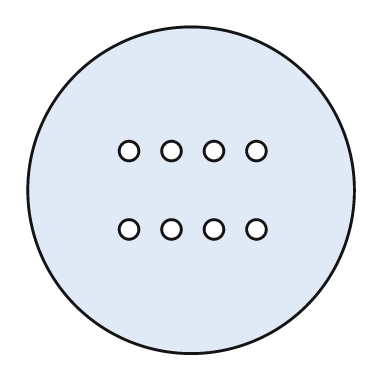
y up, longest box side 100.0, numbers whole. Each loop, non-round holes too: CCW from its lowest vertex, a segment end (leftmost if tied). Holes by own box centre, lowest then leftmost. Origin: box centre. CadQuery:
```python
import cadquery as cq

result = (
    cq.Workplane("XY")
    .moveTo(0.0, 0.0)
    .circle(50.0)
    .moveTo(-19.0, -12.0)
    .circle(3.0)
    .moveTo(-6.0, -12.0)
    .circle(3.0)
    .moveTo(7.0, -12.0)
    .circle(3.0)
    .moveTo(20.0, -12.0)
    .circle(3.0)
    .moveTo(-19.0, 12.0)
    .circle(3.0)
    .moveTo(-6.0, 12.0)
    .circle(3.0)
    .moveTo(7.0, 12.0)
    .circle(3.0)
    .moveTo(20.0, 12.0)
    .circle(3.0)
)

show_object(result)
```